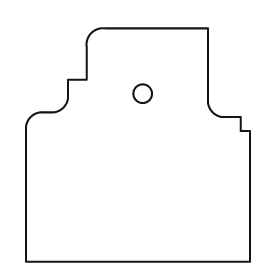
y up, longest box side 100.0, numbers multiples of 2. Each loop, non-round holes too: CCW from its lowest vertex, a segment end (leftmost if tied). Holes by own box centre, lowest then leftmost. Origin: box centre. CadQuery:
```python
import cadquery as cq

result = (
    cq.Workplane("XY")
    .moveTo(-48.0, -50.0)
    .lineTo(48.0, -50.0)
    .lineTo(48.0, 6.0)
    .lineTo(44.0, 6.0)
    .lineTo(44.0, 12.0)
    .lineTo(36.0, 12.0)
    .threePointArc((32.0, 14.0), (30.0, 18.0))
    .lineTo(30.0, 50.0)
    .lineTo(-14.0, 50.0)
    .threePointArc((-20.0, 48.0), (-22.0, 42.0))
    .lineTo(-22.0, 28.0)
    .lineTo(-30.0, 28.0)
    .lineTo(-30.0, 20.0)
    .threePointArc((-32.0, 16.0), (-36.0, 14.0))
    .lineTo(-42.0, 14.0)
    .threePointArc((-46.0, 12.0), (-48.0, 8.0))
    .close()
    .moveTo(2.0, 22.0)
    .circle(4.0)
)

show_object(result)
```